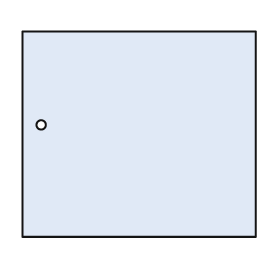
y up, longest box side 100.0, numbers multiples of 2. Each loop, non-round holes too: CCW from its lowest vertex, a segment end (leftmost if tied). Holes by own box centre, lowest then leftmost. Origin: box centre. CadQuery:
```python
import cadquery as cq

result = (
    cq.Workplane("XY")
    .moveTo(-50.0, -44.0)
    .lineTo(50.0, -44.0)
    .lineTo(50.0, 44.0)
    .lineTo(-50.0, 44.0)
    .close()
    .moveTo(-42.0, 4.0)
    .circle(2.0)
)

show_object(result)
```